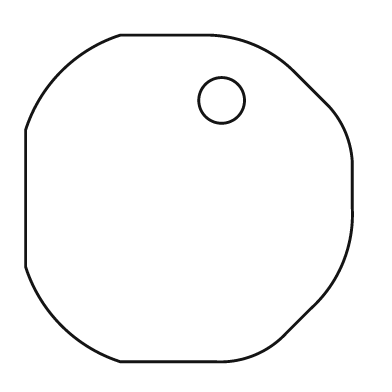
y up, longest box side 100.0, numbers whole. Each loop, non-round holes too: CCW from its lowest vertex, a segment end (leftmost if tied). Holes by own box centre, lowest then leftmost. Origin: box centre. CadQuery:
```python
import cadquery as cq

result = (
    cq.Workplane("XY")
    .moveTo(-21.0, -50.0)
    .lineTo(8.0, -50.0)
    .threePointArc((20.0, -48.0), (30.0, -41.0))
    .lineTo(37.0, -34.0)
    .threePointArc((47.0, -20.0), (50.0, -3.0))
    .lineTo(50.0, 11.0)
    .threePointArc((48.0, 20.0), (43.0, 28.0))
    .lineTo(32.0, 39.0)
    .threePointArc((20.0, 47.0), (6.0, 50.0))
    .lineTo(-21.0, 50.0)
    .threePointArc((-39.0, 39.0), (-50.0, 21.0))
    .lineTo(-50.0, -21.0)
    .threePointArc((-39.0, -39.0), (-21.0, -50.0))
    .close()
    .moveTo(10.0, 30.0)
    .circle(7.0)
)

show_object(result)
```